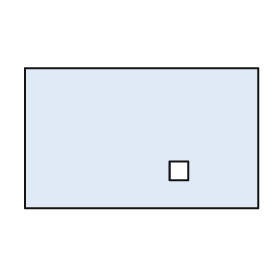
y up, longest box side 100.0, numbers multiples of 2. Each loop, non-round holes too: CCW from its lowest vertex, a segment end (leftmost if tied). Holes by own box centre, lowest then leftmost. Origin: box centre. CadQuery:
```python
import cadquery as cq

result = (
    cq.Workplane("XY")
    .moveTo(-50.0, -30.0)
    .lineTo(50.0, -30.0)
    .lineTo(50.0, 30.0)
    .lineTo(-50.0, 30.0)
    .close()
    .moveTo(12.0, -18.0)
    .lineTo(20.0, -18.0)
    .lineTo(20.0, -10.0)
    .lineTo(12.0, -10.0)
    .close()
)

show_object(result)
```